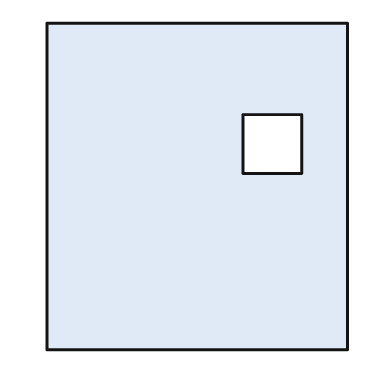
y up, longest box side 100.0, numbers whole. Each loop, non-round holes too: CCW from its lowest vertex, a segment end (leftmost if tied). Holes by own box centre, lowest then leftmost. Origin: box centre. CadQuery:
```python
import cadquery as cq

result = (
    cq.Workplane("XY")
    .moveTo(-46.0, -50.0)
    .lineTo(46.0, -50.0)
    .lineTo(46.0, 50.0)
    .lineTo(-46.0, 50.0)
    .close()
    .moveTo(14.0, 4.0)
    .lineTo(32.0, 4.0)
    .lineTo(32.0, 22.0)
    .lineTo(14.0, 22.0)
    .close()
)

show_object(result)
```